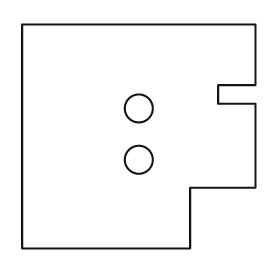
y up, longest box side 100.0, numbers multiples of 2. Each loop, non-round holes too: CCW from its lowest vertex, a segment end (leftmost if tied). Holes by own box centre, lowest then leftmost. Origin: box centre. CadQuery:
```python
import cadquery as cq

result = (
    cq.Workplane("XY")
    .moveTo(-50.0, -48.0)
    .lineTo(22.0, -48.0)
    .lineTo(22.0, -22.0)
    .lineTo(50.0, -22.0)
    .lineTo(50.0, 14.0)
    .lineTo(34.0, 14.0)
    .lineTo(34.0, 22.0)
    .lineTo(50.0, 22.0)
    .lineTo(50.0, 48.0)
    .lineTo(-50.0, 48.0)
    .close()
    .moveTo(0.0, -10.0)
    .circle(6.0)
    .moveTo(0.0, 12.0)
    .circle(6.0)
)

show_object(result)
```